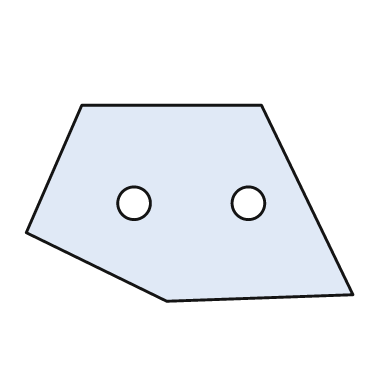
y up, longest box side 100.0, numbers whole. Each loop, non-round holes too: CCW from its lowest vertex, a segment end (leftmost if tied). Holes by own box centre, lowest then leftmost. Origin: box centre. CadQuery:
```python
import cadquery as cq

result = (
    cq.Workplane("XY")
    .moveTo(-7.0, -30.0)
    .lineTo(50.0, -28.0)
    .lineTo(22.0, 30.0)
    .lineTo(-33.0, 30.0)
    .lineTo(-50.0, -9.0)
    .close()
    .moveTo(-17.0, 0.0)
    .circle(5.0)
    .moveTo(18.0, 0.0)
    .circle(5.0)
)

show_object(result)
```